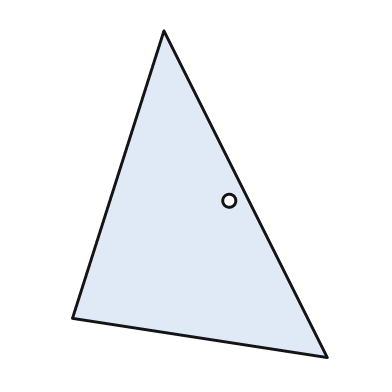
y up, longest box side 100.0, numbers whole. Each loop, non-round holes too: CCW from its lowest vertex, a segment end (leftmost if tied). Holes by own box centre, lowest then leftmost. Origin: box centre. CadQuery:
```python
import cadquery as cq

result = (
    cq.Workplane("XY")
    .moveTo(39.0, -50.0)
    .lineTo(-11.0, 50.0)
    .lineTo(-39.0, -38.0)
    .close()
    .moveTo(9.0, -2.0)
    .circle(2.0)
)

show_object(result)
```